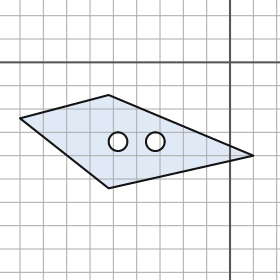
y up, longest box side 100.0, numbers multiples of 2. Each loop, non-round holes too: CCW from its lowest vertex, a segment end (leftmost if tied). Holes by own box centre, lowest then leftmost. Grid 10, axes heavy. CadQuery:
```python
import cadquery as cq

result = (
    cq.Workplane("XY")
    .moveTo(-52.0, -54.0)
    .lineTo(10.0, -40.0)
    .lineTo(-52.0, -14.0)
    .lineTo(-90.0, -24.0)
    .close()
    .moveTo(-48.0, -34.0)
    .circle(4.0)
    .moveTo(-32.0, -34.0)
    .circle(4.0)
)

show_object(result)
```